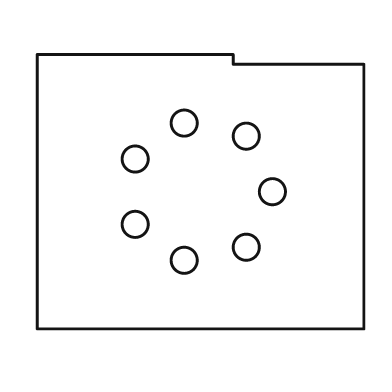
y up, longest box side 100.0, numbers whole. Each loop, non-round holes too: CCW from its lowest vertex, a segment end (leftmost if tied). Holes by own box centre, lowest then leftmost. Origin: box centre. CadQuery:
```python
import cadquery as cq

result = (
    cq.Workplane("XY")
    .moveTo(-50.0, -42.0)
    .lineTo(50.0, -42.0)
    .lineTo(50.0, 39.0)
    .lineTo(10.0, 39.0)
    .lineTo(10.0, 42.0)
    .lineTo(-50.0, 42.0)
    .close()
    .moveTo(-5.0, -21.0)
    .circle(4.0)
    .moveTo(14.0, -17.0)
    .circle(4.0)
    .moveTo(-20.0, -10.0)
    .circle(4.0)
    .moveTo(22.0, 0.0)
    .circle(4.0)
    .moveTo(-20.0, 10.0)
    .circle(4.0)
    .moveTo(14.0, 17.0)
    .circle(4.0)
    .moveTo(-5.0, 21.0)
    .circle(4.0)
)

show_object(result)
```